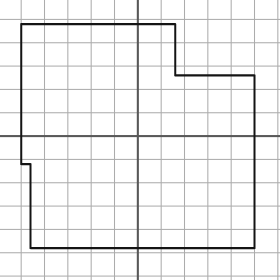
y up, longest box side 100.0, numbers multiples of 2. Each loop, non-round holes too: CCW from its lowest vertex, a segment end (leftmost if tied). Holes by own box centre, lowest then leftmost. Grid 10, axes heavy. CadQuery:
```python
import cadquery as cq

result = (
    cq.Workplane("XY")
    .moveTo(-46.0, -48.0)
    .lineTo(50.0, -48.0)
    .lineTo(50.0, 26.0)
    .lineTo(16.0, 26.0)
    .lineTo(16.0, 48.0)
    .lineTo(-50.0, 48.0)
    .lineTo(-50.0, -12.0)
    .lineTo(-46.0, -12.0)
    .close()
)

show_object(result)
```